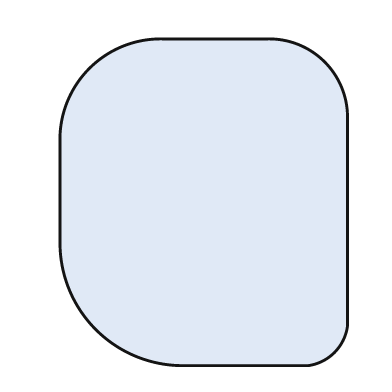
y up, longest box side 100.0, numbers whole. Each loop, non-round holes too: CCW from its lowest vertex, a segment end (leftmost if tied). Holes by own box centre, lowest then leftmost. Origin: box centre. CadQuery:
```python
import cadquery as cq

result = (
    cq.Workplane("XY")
    .moveTo(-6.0, -50.0)
    .lineTo(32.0, -50.0)
    .threePointArc((40.0, -46.0), (44.0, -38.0))
    .lineTo(44.0, 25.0)
    .threePointArc((37.0, 43.0), (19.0, 50.0))
    .lineTo(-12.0, 50.0)
    .threePointArc((-35.0, 41.0), (-44.0, 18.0))
    .lineTo(-44.0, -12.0)
    .threePointArc((-33.0, -39.0), (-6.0, -50.0))
    .close()
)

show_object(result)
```